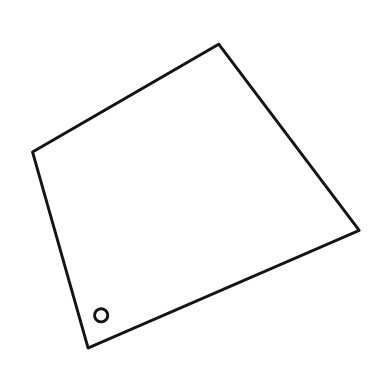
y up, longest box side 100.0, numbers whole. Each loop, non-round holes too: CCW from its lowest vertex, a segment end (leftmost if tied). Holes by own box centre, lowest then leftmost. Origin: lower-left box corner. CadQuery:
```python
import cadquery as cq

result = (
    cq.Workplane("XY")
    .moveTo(17.0, 0.0)
    .lineTo(100.0, 36.0)
    .lineTo(57.0, 93.0)
    .lineTo(0.0, 60.0)
    .close()
    .moveTo(21.0, 10.0)
    .circle(2.0)
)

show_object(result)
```